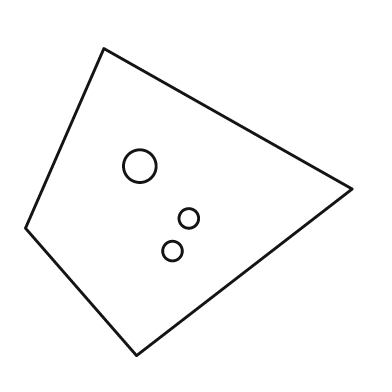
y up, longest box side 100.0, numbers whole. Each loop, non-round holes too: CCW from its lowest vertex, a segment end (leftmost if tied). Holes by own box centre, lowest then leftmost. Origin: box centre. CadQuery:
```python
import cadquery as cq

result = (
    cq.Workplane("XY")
    .moveTo(-16.0, -47.0)
    .lineTo(50.0, 4.0)
    .lineTo(-26.0, 47.0)
    .lineTo(-50.0, -8.0)
    .close()
    .moveTo(-5.0, -15.0)
    .circle(3.0)
    .moveTo(0.0, -5.0)
    .circle(3.0)
    .moveTo(-15.0, 11.0)
    .circle(5.0)
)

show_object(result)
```